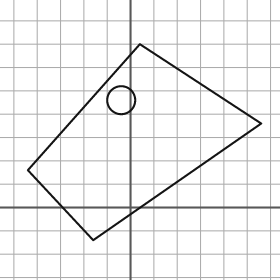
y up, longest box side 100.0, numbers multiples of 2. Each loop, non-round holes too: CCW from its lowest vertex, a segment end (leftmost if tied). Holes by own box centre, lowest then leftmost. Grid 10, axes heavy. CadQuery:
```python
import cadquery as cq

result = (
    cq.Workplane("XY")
    .moveTo(-16.0, -14.0)
    .lineTo(56.0, 36.0)
    .lineTo(4.0, 70.0)
    .lineTo(-44.0, 16.0)
    .close()
    .moveTo(-4.0, 46.0)
    .circle(6.0)
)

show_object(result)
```